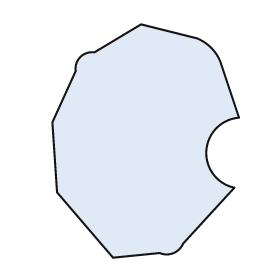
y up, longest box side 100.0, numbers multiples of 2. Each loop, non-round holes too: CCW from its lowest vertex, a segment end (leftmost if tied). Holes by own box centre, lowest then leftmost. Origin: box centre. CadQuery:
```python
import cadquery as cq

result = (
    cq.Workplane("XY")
    .moveTo(-14.0, -50.0)
    .lineTo(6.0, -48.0)
    .threePointArc((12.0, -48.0), (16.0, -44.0))
    .lineTo(38.0, -20.0)
    .threePointArc((26.0, -4.0), (40.0, 10.0))
    .lineTo(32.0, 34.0)
    .threePointArc((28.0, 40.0), (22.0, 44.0))
    .lineTo(-2.0, 50.0)
    .lineTo(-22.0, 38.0)
    .threePointArc((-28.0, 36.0), (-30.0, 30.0))
    .lineTo(-40.0, 8.0)
    .lineTo(-38.0, -22.0)
    .close()
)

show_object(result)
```